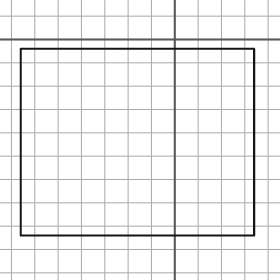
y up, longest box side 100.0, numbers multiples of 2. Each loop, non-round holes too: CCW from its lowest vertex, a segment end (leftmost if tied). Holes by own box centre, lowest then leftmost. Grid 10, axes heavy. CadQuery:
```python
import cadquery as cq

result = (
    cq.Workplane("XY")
    .moveTo(-66.0, -84.0)
    .lineTo(34.0, -84.0)
    .lineTo(34.0, -4.0)
    .lineTo(-66.0, -4.0)
    .close()
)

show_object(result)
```